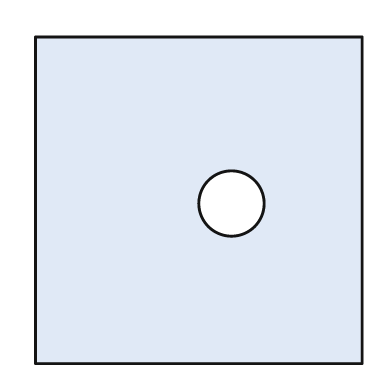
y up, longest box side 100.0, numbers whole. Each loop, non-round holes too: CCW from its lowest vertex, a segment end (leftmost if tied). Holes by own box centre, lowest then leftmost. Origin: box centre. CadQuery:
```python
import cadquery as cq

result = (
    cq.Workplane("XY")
    .moveTo(-50.0, -50.0)
    .lineTo(50.0, -50.0)
    .lineTo(50.0, 50.0)
    .lineTo(-50.0, 50.0)
    .close()
    .moveTo(10.0, -1.0)
    .circle(10.0)
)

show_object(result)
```